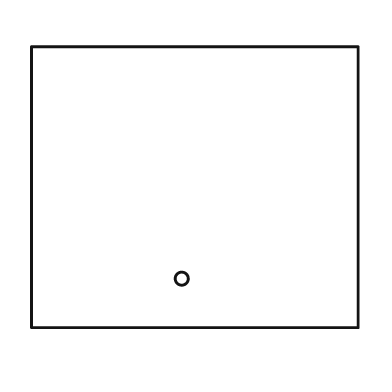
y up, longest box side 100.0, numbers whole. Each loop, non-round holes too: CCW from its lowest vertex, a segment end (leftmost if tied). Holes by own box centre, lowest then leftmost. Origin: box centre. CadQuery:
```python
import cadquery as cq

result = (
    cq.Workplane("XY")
    .moveTo(-50.0, -43.0)
    .lineTo(50.0, -43.0)
    .lineTo(50.0, 43.0)
    .lineTo(-50.0, 43.0)
    .close()
    .moveTo(-4.0, -28.0)
    .circle(2.0)
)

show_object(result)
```